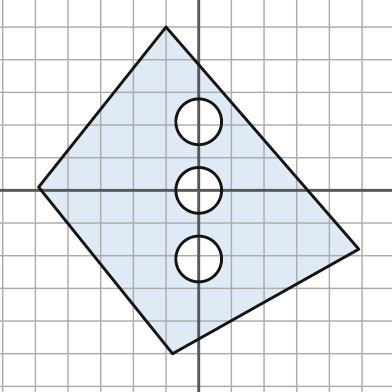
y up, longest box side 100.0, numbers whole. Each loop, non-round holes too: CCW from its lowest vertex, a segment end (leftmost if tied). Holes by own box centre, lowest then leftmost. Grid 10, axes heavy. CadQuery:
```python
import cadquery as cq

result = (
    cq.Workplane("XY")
    .moveTo(-8.0, -50.0)
    .lineTo(49.0, -18.0)
    .lineTo(-10.0, 50.0)
    .lineTo(-49.0, 1.0)
    .close()
    .moveTo(0.0, -21.0)
    .circle(7.0)
    .moveTo(0.0, 0.0)
    .circle(7.0)
    .moveTo(0.0, 21.0)
    .circle(7.0)
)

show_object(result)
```